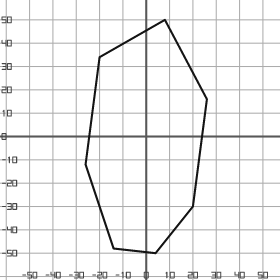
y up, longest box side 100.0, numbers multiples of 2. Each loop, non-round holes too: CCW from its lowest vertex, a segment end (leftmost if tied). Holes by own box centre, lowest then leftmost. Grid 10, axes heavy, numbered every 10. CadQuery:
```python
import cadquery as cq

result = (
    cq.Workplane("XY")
    .moveTo(4.0, -50.0)
    .lineTo(20.0, -30.0)
    .lineTo(26.0, 16.0)
    .lineTo(8.0, 50.0)
    .lineTo(-20.0, 34.0)
    .lineTo(-26.0, -12.0)
    .lineTo(-14.0, -48.0)
    .close()
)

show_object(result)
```